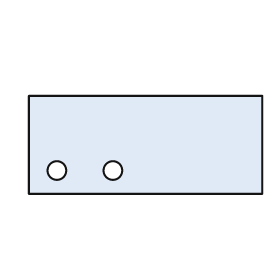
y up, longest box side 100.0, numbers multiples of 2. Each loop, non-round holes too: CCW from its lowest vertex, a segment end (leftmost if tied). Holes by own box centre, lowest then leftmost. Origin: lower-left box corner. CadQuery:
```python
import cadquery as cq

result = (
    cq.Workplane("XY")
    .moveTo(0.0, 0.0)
    .lineTo(100.0, 0.0)
    .lineTo(100.0, 42.0)
    .lineTo(0.0, 42.0)
    .close()
    .moveTo(12.0, 10.0)
    .circle(4.0)
    .moveTo(36.0, 10.0)
    .circle(4.0)
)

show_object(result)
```